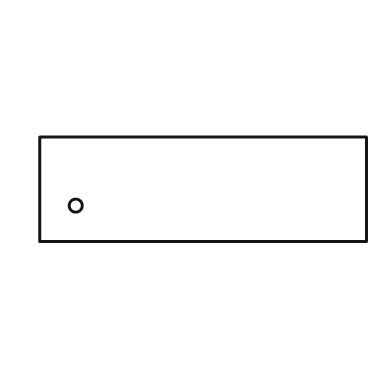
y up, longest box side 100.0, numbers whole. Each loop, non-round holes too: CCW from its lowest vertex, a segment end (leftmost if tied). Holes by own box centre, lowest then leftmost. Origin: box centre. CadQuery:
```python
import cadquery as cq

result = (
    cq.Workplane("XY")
    .moveTo(-50.0, -16.0)
    .lineTo(50.0, -16.0)
    .lineTo(50.0, 16.0)
    .lineTo(-50.0, 16.0)
    .close()
    .moveTo(-39.0, -5.0)
    .circle(2.0)
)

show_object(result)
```